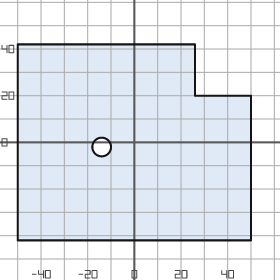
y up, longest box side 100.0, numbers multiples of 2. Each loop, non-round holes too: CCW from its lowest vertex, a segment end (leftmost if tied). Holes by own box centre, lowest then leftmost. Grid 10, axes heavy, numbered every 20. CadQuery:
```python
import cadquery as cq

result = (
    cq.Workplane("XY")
    .moveTo(-50.0, -42.0)
    .lineTo(50.0, -42.0)
    .lineTo(50.0, 20.0)
    .lineTo(26.0, 20.0)
    .lineTo(26.0, 42.0)
    .lineTo(-50.0, 42.0)
    .close()
    .moveTo(-14.0, -2.0)
    .circle(4.0)
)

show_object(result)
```